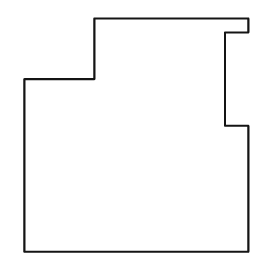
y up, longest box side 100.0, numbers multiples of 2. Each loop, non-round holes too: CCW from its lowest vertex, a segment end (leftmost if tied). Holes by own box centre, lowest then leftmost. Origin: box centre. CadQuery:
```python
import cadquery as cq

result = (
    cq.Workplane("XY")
    .moveTo(-48.0, -50.0)
    .lineTo(48.0, -50.0)
    .lineTo(48.0, 4.0)
    .lineTo(38.0, 4.0)
    .lineTo(38.0, 44.0)
    .lineTo(48.0, 44.0)
    .lineTo(48.0, 50.0)
    .lineTo(-18.0, 50.0)
    .lineTo(-18.0, 24.0)
    .lineTo(-48.0, 24.0)
    .close()
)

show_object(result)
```